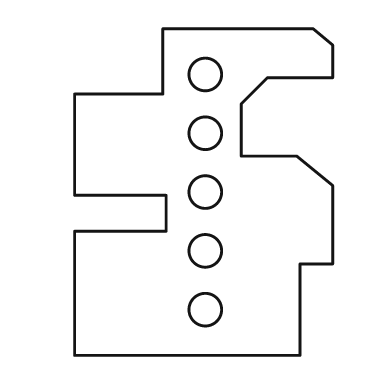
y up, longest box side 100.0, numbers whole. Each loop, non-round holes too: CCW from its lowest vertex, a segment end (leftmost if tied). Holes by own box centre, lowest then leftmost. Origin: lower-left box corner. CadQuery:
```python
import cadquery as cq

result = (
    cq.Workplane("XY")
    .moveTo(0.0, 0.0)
    .lineTo(69.0, 0.0)
    .lineTo(69.0, 28.0)
    .lineTo(79.0, 28.0)
    .lineTo(79.0, 52.0)
    .lineTo(68.0, 61.0)
    .lineTo(51.0, 61.0)
    .lineTo(51.0, 77.0)
    .lineTo(59.0, 85.0)
    .lineTo(79.0, 85.0)
    .lineTo(79.0, 95.0)
    .lineTo(73.0, 100.0)
    .lineTo(27.0, 100.0)
    .lineTo(27.0, 80.0)
    .lineTo(0.0, 80.0)
    .lineTo(0.0, 49.0)
    .lineTo(28.0, 49.0)
    .lineTo(28.0, 38.0)
    .lineTo(0.0, 38.0)
    .close()
    .moveTo(40.0, 14.0)
    .circle(5.0)
    .moveTo(40.0, 32.0)
    .circle(5.0)
    .moveTo(40.0, 50.0)
    .circle(5.0)
    .moveTo(40.0, 68.0)
    .circle(5.0)
    .moveTo(40.0, 86.0)
    .circle(5.0)
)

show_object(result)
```